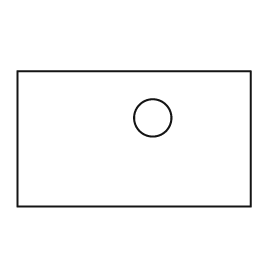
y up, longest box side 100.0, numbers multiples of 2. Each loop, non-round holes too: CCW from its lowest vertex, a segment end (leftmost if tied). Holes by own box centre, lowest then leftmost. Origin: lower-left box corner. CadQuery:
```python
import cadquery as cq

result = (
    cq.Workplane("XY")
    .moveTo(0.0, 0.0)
    .lineTo(100.0, 0.0)
    .lineTo(100.0, 58.0)
    .lineTo(0.0, 58.0)
    .close()
    .moveTo(58.0, 38.0)
    .circle(8.0)
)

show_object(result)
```